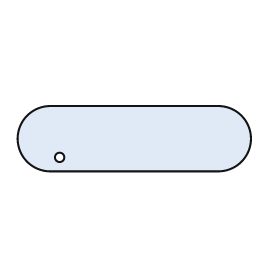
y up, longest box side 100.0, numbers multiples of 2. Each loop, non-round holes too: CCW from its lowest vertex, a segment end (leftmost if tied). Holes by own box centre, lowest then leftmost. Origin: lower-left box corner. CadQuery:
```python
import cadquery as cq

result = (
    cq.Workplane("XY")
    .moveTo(14.0, 0.0)
    .lineTo(86.0, 0.0)
    .threePointArc((100.0, 14.0), (86.0, 28.0))
    .lineTo(14.0, 28.0)
    .threePointArc((0.0, 14.0), (14.0, 0.0))
    .close()
    .moveTo(18.0, 6.0)
    .circle(2.0)
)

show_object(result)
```